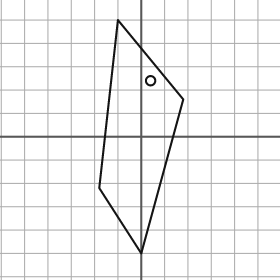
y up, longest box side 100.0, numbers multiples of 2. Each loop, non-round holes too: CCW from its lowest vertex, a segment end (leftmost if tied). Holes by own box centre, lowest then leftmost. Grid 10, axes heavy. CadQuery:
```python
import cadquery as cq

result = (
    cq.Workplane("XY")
    .moveTo(0.0, -50.0)
    .lineTo(18.0, 16.0)
    .lineTo(-10.0, 50.0)
    .lineTo(-18.0, -22.0)
    .close()
    .moveTo(4.0, 24.0)
    .circle(2.0)
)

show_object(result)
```